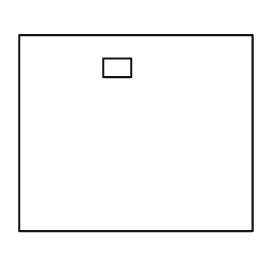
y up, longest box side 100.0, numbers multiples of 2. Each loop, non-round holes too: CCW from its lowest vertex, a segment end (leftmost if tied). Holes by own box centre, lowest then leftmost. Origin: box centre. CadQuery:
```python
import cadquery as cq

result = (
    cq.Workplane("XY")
    .moveTo(-50.0, -42.0)
    .lineTo(50.0, -42.0)
    .lineTo(50.0, 42.0)
    .lineTo(-50.0, 42.0)
    .close()
    .moveTo(-14.0, 24.0)
    .lineTo(-2.0, 24.0)
    .lineTo(-2.0, 32.0)
    .lineTo(-14.0, 32.0)
    .close()
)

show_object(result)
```